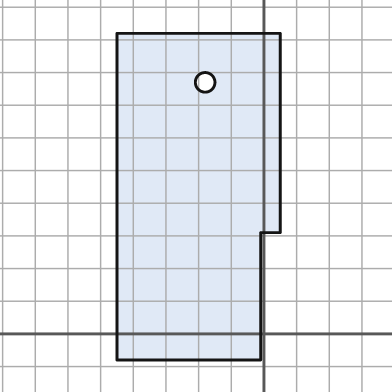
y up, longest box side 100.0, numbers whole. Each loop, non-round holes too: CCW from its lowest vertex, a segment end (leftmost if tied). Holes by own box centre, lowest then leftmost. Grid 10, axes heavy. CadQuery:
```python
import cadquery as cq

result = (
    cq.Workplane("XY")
    .moveTo(-45.0, -8.0)
    .lineTo(-1.0, -8.0)
    .lineTo(-1.0, 31.0)
    .lineTo(5.0, 31.0)
    .lineTo(5.0, 92.0)
    .lineTo(-45.0, 92.0)
    .close()
    .moveTo(-18.0, 77.0)
    .circle(3.0)
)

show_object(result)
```